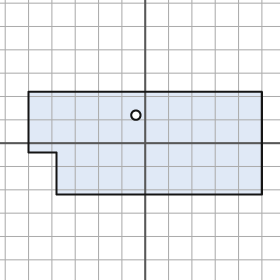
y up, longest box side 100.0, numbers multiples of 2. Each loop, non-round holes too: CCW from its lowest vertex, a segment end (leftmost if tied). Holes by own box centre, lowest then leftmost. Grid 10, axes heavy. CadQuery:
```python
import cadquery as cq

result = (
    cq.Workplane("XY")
    .moveTo(-38.0, -22.0)
    .lineTo(50.0, -22.0)
    .lineTo(50.0, 22.0)
    .lineTo(-50.0, 22.0)
    .lineTo(-50.0, -4.0)
    .lineTo(-38.0, -4.0)
    .close()
    .moveTo(-4.0, 12.0)
    .circle(2.0)
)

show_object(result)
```